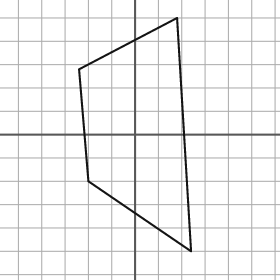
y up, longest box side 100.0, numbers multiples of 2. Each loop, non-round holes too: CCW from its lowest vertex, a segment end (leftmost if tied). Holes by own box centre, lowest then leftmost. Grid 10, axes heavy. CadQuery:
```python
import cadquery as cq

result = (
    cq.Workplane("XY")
    .moveTo(24.0, -50.0)
    .lineTo(18.0, 50.0)
    .lineTo(-24.0, 28.0)
    .lineTo(-20.0, -20.0)
    .close()
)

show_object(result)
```